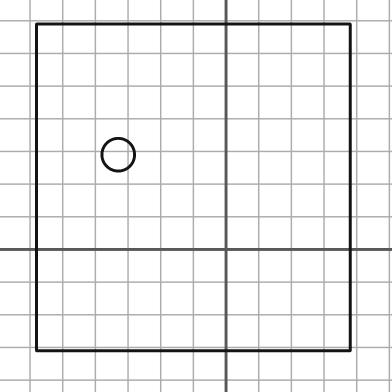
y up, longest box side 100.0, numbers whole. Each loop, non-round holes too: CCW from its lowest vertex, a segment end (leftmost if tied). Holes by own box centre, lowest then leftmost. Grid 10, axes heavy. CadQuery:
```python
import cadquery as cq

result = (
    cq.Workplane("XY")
    .moveTo(-58.0, -31.0)
    .lineTo(38.0, -31.0)
    .lineTo(38.0, 69.0)
    .lineTo(-58.0, 69.0)
    .close()
    .moveTo(-33.0, 29.0)
    .circle(5.0)
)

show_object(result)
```